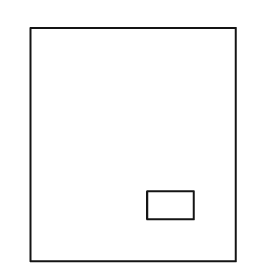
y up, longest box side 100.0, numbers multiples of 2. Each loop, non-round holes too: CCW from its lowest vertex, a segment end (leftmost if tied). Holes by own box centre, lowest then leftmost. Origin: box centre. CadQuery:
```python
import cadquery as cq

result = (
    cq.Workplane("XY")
    .moveTo(-44.0, -50.0)
    .lineTo(44.0, -50.0)
    .lineTo(44.0, 50.0)
    .lineTo(-44.0, 50.0)
    .close()
    .moveTo(6.0, -32.0)
    .lineTo(26.0, -32.0)
    .lineTo(26.0, -20.0)
    .lineTo(6.0, -20.0)
    .close()
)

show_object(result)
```